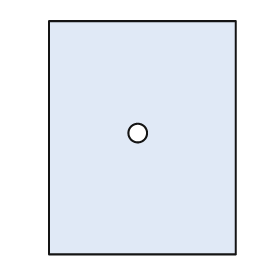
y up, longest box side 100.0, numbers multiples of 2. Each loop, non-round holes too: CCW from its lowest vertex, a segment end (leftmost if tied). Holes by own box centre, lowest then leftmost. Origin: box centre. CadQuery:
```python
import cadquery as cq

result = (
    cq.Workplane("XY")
    .moveTo(-40.0, -50.0)
    .lineTo(40.0, -50.0)
    .lineTo(40.0, 50.0)
    .lineTo(-40.0, 50.0)
    .close()
    .moveTo(-2.0, 2.0)
    .circle(4.0)
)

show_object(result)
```